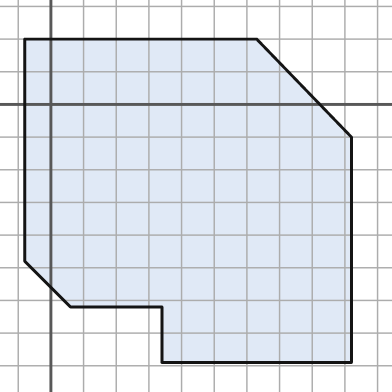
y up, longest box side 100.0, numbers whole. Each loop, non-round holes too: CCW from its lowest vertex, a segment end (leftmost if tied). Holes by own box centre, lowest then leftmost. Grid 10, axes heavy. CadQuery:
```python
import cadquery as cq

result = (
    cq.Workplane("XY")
    .moveTo(34.0, -79.0)
    .lineTo(92.0, -79.0)
    .lineTo(92.0, -10.0)
    .lineTo(63.0, 20.0)
    .lineTo(-8.0, 20.0)
    .lineTo(-8.0, -48.0)
    .lineTo(6.0, -62.0)
    .lineTo(34.0, -62.0)
    .close()
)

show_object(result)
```